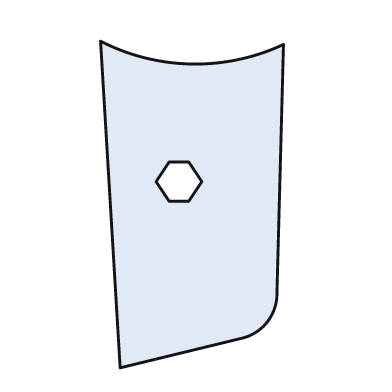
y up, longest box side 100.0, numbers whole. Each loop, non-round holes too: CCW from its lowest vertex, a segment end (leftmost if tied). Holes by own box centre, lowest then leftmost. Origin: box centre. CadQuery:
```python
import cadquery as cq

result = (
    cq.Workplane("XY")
    .moveTo(-22.0, -50.0)
    .lineTo(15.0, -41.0)
    .threePointArc((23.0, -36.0), (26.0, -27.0))
    .lineTo(28.0, 49.0)
    .threePointArc((0.0, 43.0), (-28.0, 50.0))
    .close()
    .moveTo(-7.0, 1.0)
    .lineTo(-1.0, 1.0)
    .lineTo(3.0, 7.0)
    .lineTo(-1.0, 13.0)
    .lineTo(-7.0, 13.0)
    .lineTo(-11.0, 7.0)
    .close()
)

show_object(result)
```